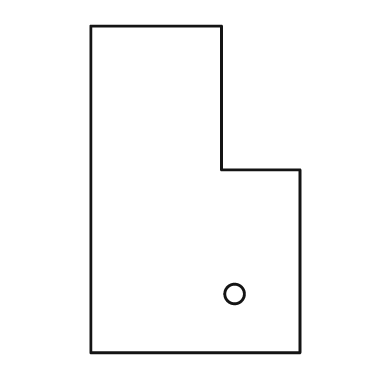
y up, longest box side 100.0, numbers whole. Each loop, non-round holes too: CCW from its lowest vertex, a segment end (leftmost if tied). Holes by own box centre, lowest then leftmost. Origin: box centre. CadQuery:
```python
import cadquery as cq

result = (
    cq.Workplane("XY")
    .moveTo(-32.0, -50.0)
    .lineTo(32.0, -50.0)
    .lineTo(32.0, 6.0)
    .lineTo(8.0, 6.0)
    .lineTo(8.0, 50.0)
    .lineTo(-32.0, 50.0)
    .close()
    .moveTo(12.0, -32.0)
    .circle(3.0)
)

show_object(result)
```